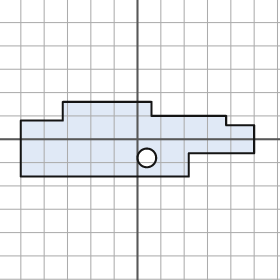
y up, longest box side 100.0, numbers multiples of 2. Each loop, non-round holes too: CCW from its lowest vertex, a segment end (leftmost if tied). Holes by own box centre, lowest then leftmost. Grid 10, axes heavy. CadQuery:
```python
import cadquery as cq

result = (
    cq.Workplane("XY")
    .moveTo(-50.0, -16.0)
    .lineTo(22.0, -16.0)
    .lineTo(22.0, -6.0)
    .lineTo(50.0, -6.0)
    .lineTo(50.0, 6.0)
    .lineTo(38.0, 6.0)
    .lineTo(38.0, 10.0)
    .lineTo(6.0, 10.0)
    .lineTo(6.0, 16.0)
    .lineTo(-32.0, 16.0)
    .lineTo(-32.0, 8.0)
    .lineTo(-50.0, 8.0)
    .close()
    .moveTo(4.0, -8.0)
    .circle(4.0)
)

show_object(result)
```